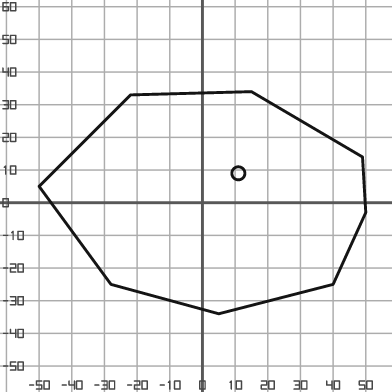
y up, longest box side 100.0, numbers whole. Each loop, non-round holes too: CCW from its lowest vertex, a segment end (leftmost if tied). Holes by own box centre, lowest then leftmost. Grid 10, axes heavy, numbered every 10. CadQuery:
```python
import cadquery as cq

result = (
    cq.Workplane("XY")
    .moveTo(5.0, -34.0)
    .lineTo(40.0, -25.0)
    .lineTo(50.0, -3.0)
    .lineTo(49.0, 14.0)
    .lineTo(15.0, 34.0)
    .lineTo(-22.0, 33.0)
    .lineTo(-50.0, 5.0)
    .lineTo(-28.0, -25.0)
    .close()
    .moveTo(11.0, 9.0)
    .circle(2.0)
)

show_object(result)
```